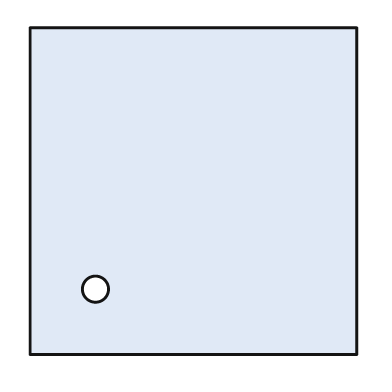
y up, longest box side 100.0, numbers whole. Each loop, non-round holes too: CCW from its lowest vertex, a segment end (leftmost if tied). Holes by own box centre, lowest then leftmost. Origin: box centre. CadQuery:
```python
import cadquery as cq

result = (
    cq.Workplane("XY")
    .moveTo(-50.0, -50.0)
    .lineTo(50.0, -50.0)
    .lineTo(50.0, 50.0)
    .lineTo(-50.0, 50.0)
    .close()
    .moveTo(-30.0, -30.0)
    .circle(4.0)
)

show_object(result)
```